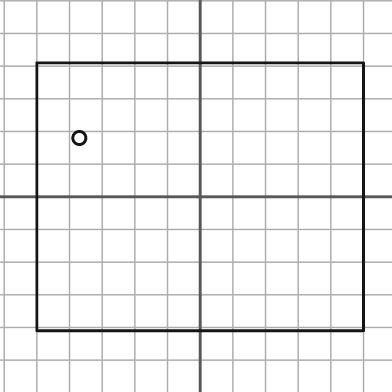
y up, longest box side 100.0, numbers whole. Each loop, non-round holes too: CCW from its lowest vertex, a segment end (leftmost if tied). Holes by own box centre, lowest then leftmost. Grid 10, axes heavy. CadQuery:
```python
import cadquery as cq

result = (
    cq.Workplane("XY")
    .moveTo(-50.0, -41.0)
    .lineTo(50.0, -41.0)
    .lineTo(50.0, 41.0)
    .lineTo(-50.0, 41.0)
    .close()
    .moveTo(-37.0, 18.0)
    .circle(2.0)
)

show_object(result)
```